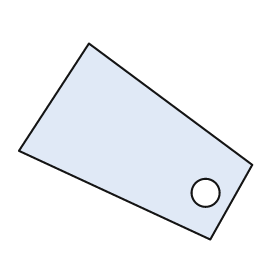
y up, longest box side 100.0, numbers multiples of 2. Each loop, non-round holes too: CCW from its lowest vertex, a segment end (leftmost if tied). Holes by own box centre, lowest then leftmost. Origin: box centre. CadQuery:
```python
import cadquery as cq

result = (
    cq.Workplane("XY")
    .moveTo(32.0, -42.0)
    .lineTo(50.0, -10.0)
    .lineTo(-20.0, 42.0)
    .lineTo(-50.0, -4.0)
    .close()
    .moveTo(30.0, -22.0)
    .circle(6.0)
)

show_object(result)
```